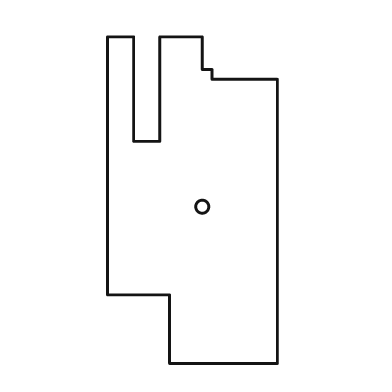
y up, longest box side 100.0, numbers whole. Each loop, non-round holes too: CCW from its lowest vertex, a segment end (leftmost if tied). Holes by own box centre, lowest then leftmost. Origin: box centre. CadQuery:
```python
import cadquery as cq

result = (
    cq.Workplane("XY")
    .moveTo(-7.0, -50.0)
    .lineTo(26.0, -50.0)
    .lineTo(26.0, 37.0)
    .lineTo(6.0, 37.0)
    .lineTo(6.0, 40.0)
    .lineTo(3.0, 40.0)
    .lineTo(3.0, 50.0)
    .lineTo(-10.0, 50.0)
    .lineTo(-10.0, 18.0)
    .lineTo(-18.0, 18.0)
    .lineTo(-18.0, 50.0)
    .lineTo(-26.0, 50.0)
    .lineTo(-26.0, -29.0)
    .lineTo(-7.0, -29.0)
    .close()
    .moveTo(3.0, -2.0)
    .circle(2.0)
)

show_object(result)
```